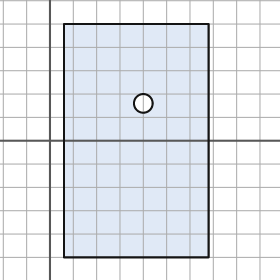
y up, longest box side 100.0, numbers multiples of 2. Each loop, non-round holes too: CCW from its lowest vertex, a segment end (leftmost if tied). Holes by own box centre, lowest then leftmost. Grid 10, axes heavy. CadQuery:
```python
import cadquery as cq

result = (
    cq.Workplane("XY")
    .moveTo(6.0, -50.0)
    .lineTo(68.0, -50.0)
    .lineTo(68.0, 50.0)
    .lineTo(6.0, 50.0)
    .close()
    .moveTo(40.0, 16.0)
    .circle(4.0)
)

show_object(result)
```